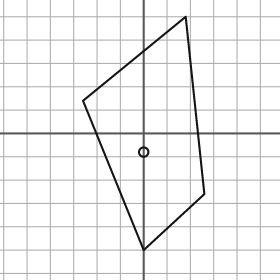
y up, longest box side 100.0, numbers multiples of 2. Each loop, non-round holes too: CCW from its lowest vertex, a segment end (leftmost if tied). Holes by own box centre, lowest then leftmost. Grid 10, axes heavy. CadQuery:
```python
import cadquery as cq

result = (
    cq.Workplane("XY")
    .moveTo(0.0, -50.0)
    .lineTo(26.0, -26.0)
    .lineTo(18.0, 50.0)
    .lineTo(-26.0, 14.0)
    .close()
    .moveTo(0.0, -8.0)
    .circle(2.0)
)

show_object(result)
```